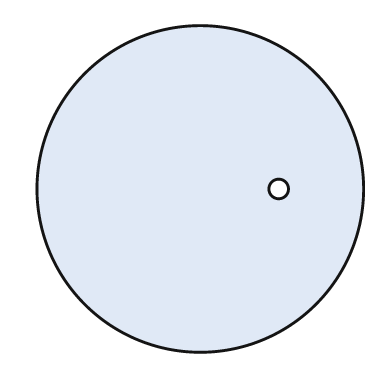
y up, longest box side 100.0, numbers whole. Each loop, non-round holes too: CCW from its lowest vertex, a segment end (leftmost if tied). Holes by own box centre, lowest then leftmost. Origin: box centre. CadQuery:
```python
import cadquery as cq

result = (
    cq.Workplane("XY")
    .moveTo(0.0, 0.0)
    .circle(50.0)
    .moveTo(24.0, 0.0)
    .circle(3.0)
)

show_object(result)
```